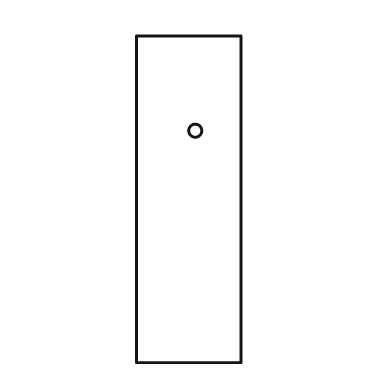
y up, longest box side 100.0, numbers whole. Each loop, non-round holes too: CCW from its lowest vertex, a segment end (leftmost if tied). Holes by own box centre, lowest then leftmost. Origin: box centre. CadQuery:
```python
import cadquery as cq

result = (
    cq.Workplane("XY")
    .moveTo(-16.0, -50.0)
    .lineTo(16.0, -50.0)
    .lineTo(16.0, 50.0)
    .lineTo(-16.0, 50.0)
    .close()
    .moveTo(2.0, 21.0)
    .circle(2.0)
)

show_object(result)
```